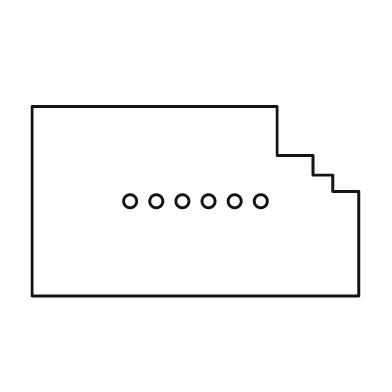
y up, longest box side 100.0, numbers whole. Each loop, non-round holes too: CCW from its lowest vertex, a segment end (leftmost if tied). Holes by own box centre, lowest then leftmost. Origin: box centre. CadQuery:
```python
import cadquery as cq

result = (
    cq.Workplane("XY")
    .moveTo(-50.0, -29.0)
    .lineTo(50.0, -29.0)
    .lineTo(50.0, 3.0)
    .lineTo(42.0, 3.0)
    .lineTo(42.0, 8.0)
    .lineTo(36.0, 8.0)
    .lineTo(36.0, 14.0)
    .lineTo(25.0, 14.0)
    .lineTo(25.0, 29.0)
    .lineTo(-50.0, 29.0)
    .close()
    .moveTo(-20.0, 0.0)
    .circle(2.0)
    .moveTo(-12.0, 0.0)
    .circle(2.0)
    .moveTo(-4.0, 0.0)
    .circle(2.0)
    .moveTo(4.0, 0.0)
    .circle(2.0)
    .moveTo(12.0, 0.0)
    .circle(2.0)
    .moveTo(20.0, 0.0)
    .circle(2.0)
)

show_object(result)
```